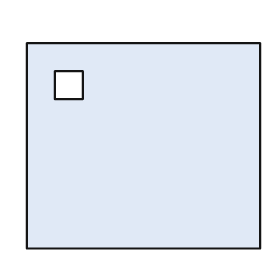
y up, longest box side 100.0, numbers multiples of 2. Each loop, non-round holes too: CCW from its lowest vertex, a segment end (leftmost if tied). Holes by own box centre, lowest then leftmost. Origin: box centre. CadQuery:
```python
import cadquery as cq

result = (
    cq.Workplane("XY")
    .moveTo(-50.0, -44.0)
    .lineTo(50.0, -44.0)
    .lineTo(50.0, 44.0)
    .lineTo(-50.0, 44.0)
    .close()
    .moveTo(-38.0, 20.0)
    .lineTo(-26.0, 20.0)
    .lineTo(-26.0, 32.0)
    .lineTo(-38.0, 32.0)
    .close()
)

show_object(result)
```